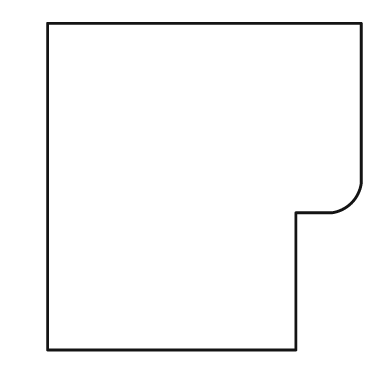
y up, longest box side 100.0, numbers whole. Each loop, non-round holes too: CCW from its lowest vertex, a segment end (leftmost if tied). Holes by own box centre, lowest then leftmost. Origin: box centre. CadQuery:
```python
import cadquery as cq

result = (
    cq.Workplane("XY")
    .moveTo(-48.0, -50.0)
    .lineTo(28.0, -50.0)
    .lineTo(28.0, -8.0)
    .lineTo(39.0, -8.0)
    .threePointArc((45.0, -5.0), (48.0, 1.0))
    .lineTo(48.0, 50.0)
    .lineTo(-48.0, 50.0)
    .close()
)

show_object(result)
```